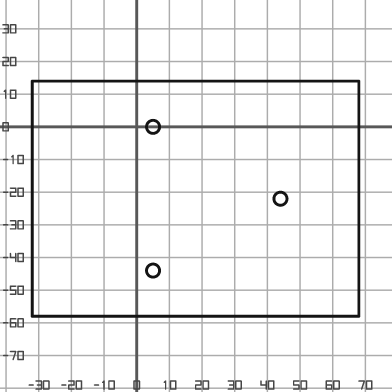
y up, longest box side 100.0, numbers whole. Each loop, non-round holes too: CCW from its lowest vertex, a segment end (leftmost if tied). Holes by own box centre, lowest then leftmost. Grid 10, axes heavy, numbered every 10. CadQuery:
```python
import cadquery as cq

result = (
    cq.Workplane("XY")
    .moveTo(-32.0, -58.0)
    .lineTo(68.0, -58.0)
    .lineTo(68.0, 14.0)
    .lineTo(-32.0, 14.0)
    .close()
    .moveTo(5.0, -44.0)
    .circle(2.0)
    .moveTo(44.0, -22.0)
    .circle(2.0)
    .moveTo(5.0, 0.0)
    .circle(2.0)
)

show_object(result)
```